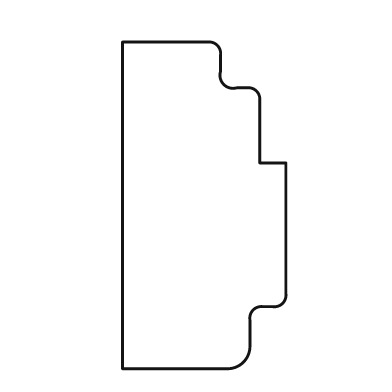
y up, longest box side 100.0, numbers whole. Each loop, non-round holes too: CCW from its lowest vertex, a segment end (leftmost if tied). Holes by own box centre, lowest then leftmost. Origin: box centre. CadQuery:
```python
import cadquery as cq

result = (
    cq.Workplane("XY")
    .moveTo(-25.0, -50.0)
    .lineTo(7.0, -50.0)
    .threePointArc((12.0, -48.0), (14.0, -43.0))
    .lineTo(14.0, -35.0)
    .threePointArc((15.0, -32.0), (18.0, -31.0))
    .lineTo(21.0, -31.0)
    .threePointArc((24.0, -30.0), (25.0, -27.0))
    .lineTo(25.0, 13.0)
    .lineTo(17.0, 13.0)
    .lineTo(17.0, 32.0)
    .threePointArc((16.0, 35.0), (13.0, 36.0))
    .lineTo(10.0, 36.0)
    .threePointArc((6.0, 37.0), (5.0, 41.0))
    .lineTo(5.0, 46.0)
    .threePointArc((4.0, 49.0), (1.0, 50.0))
    .lineTo(-25.0, 50.0)
    .close()
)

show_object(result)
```